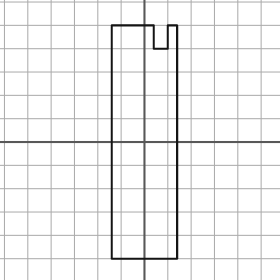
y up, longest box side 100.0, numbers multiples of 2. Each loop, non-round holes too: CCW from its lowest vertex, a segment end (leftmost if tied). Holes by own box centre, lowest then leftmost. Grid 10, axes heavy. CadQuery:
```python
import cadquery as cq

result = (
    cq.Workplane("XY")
    .moveTo(-14.0, -50.0)
    .lineTo(14.0, -50.0)
    .lineTo(14.0, 50.0)
    .lineTo(10.0, 50.0)
    .lineTo(10.0, 40.0)
    .lineTo(4.0, 40.0)
    .lineTo(4.0, 50.0)
    .lineTo(-14.0, 50.0)
    .close()
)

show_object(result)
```